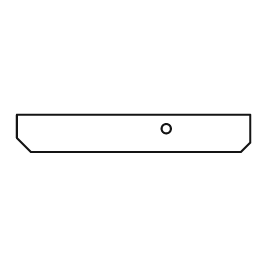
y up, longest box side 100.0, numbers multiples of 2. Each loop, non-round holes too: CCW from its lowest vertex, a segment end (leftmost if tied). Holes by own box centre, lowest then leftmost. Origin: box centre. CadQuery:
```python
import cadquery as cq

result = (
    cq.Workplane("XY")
    .moveTo(-44.0, -8.0)
    .lineTo(46.0, -8.0)
    .lineTo(50.0, -4.0)
    .lineTo(50.0, 8.0)
    .lineTo(-50.0, 8.0)
    .lineTo(-50.0, -2.0)
    .close()
    .moveTo(14.0, 2.0)
    .circle(2.0)
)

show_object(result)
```